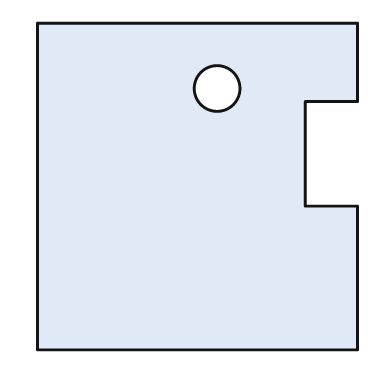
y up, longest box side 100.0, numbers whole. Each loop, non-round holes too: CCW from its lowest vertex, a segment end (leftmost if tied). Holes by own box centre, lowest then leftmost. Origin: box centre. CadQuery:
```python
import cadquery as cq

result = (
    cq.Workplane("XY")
    .moveTo(-49.0, -50.0)
    .lineTo(49.0, -50.0)
    .lineTo(49.0, -6.0)
    .lineTo(33.0, -6.0)
    .lineTo(33.0, 26.0)
    .lineTo(49.0, 26.0)
    .lineTo(49.0, 50.0)
    .lineTo(-49.0, 50.0)
    .close()
    .moveTo(6.0, 30.0)
    .circle(7.0)
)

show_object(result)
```